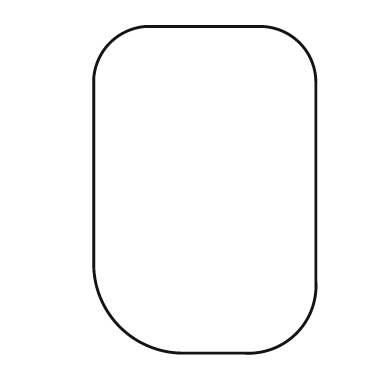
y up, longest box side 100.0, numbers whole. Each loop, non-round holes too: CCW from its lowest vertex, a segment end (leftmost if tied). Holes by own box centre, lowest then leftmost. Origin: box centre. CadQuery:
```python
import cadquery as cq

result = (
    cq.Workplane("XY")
    .moveTo(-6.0, -50.0)
    .lineTo(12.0, -50.0)
    .threePointArc((28.0, -44.0), (34.0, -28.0))
    .lineTo(34.0, 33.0)
    .threePointArc((29.0, 45.0), (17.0, 50.0))
    .lineTo(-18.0, 50.0)
    .threePointArc((-29.0, 45.0), (-34.0, 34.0))
    .lineTo(-34.0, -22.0)
    .threePointArc((-26.0, -42.0), (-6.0, -50.0))
    .close()
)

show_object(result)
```